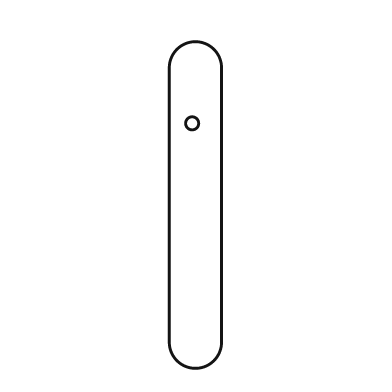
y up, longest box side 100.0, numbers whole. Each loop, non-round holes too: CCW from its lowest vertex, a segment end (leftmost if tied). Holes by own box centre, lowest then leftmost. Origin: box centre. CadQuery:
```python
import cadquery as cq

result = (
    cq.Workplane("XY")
    .moveTo(-8.0, -42.0)
    .threePointArc((0.0, -50.0), (8.0, -42.0))
    .lineTo(8.0, 42.0)
    .threePointArc((0.0, 50.0), (-8.0, 42.0))
    .close()
    .moveTo(-1.0, 25.0)
    .circle(2.0)
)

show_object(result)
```